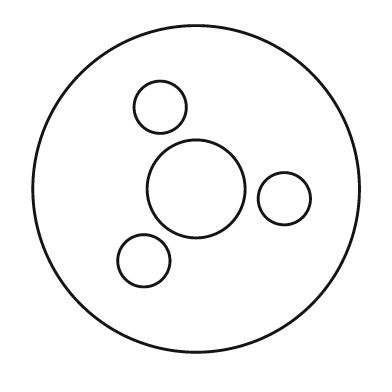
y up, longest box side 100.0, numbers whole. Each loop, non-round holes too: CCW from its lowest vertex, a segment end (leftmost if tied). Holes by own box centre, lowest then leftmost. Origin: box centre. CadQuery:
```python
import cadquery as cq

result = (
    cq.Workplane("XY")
    .moveTo(0.0, 0.0)
    .circle(50.0)
    .moveTo(-16.0, -22.0)
    .circle(8.0)
    .moveTo(27.0, -3.0)
    .circle(8.0)
    .moveTo(0.0, 0.0)
    .circle(15.0)
    .moveTo(-11.0, 25.0)
    .circle(8.0)
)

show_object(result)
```